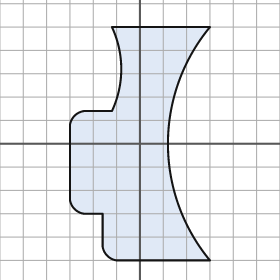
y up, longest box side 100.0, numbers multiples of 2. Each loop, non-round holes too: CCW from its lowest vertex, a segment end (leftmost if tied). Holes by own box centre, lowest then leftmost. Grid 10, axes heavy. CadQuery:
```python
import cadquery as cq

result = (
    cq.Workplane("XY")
    .moveTo(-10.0, -50.0)
    .lineTo(30.0, -50.0)
    .threePointArc((12.0, 0.0), (30.0, 50.0))
    .lineTo(-12.0, 50.0)
    .threePointArc((-8.0, 32.0), (-12.0, 14.0))
    .lineTo(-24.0, 14.0)
    .threePointArc((-28.0, 12.0), (-30.0, 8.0))
    .lineTo(-30.0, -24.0)
    .threePointArc((-28.0, -28.0), (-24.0, -30.0))
    .lineTo(-16.0, -30.0)
    .lineTo(-16.0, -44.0)
    .threePointArc((-14.0, -48.0), (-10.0, -50.0))
    .close()
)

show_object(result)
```